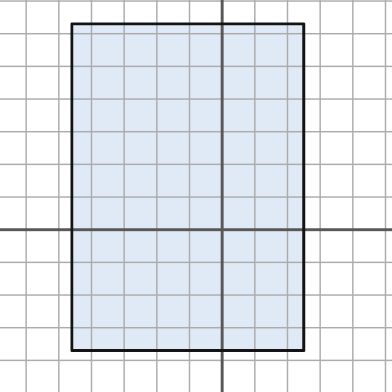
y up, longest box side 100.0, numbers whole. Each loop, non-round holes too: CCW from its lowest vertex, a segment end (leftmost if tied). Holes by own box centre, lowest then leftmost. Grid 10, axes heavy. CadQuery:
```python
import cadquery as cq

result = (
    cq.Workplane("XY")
    .moveTo(-46.0, -37.0)
    .lineTo(25.0, -37.0)
    .lineTo(25.0, 63.0)
    .lineTo(-46.0, 63.0)
    .close()
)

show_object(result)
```